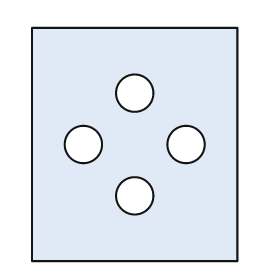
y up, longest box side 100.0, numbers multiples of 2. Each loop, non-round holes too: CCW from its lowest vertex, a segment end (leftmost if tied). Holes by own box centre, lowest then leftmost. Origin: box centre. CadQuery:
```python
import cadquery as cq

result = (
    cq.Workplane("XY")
    .moveTo(-44.0, -50.0)
    .lineTo(44.0, -50.0)
    .lineTo(44.0, 50.0)
    .lineTo(-44.0, 50.0)
    .close()
    .moveTo(0.0, -22.0)
    .circle(8.0)
    .moveTo(-22.0, 0.0)
    .circle(8.0)
    .moveTo(22.0, 0.0)
    .circle(8.0)
    .moveTo(0.0, 22.0)
    .circle(8.0)
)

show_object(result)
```